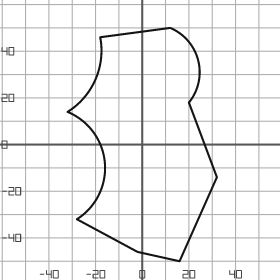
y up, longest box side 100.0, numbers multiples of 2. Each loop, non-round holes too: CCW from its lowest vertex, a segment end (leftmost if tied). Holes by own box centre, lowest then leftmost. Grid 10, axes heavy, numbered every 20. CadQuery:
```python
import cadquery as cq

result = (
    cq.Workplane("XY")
    .moveTo(16.0, -50.0)
    .lineTo(32.0, -14.0)
    .lineTo(20.0, 18.0)
    .threePointArc((24.0, 36.0), (12.0, 50.0))
    .lineTo(-18.0, 46.0)
    .threePointArc((-20.0, 28.0), (-32.0, 14.0))
    .threePointArc((-16.0, -8.0), (-28.0, -32.0))
    .lineTo(-2.0, -46.0)
    .close()
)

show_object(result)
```